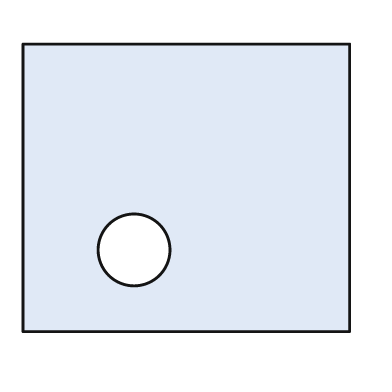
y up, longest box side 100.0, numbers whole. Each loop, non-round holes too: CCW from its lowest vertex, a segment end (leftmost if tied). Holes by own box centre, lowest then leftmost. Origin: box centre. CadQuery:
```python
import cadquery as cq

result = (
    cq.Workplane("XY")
    .moveTo(-50.0, -44.0)
    .lineTo(50.0, -44.0)
    .lineTo(50.0, 44.0)
    .lineTo(-50.0, 44.0)
    .close()
    .moveTo(-16.0, -19.0)
    .circle(11.0)
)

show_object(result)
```